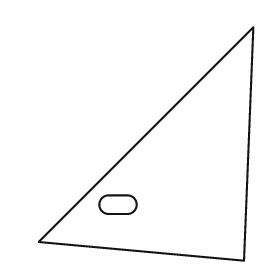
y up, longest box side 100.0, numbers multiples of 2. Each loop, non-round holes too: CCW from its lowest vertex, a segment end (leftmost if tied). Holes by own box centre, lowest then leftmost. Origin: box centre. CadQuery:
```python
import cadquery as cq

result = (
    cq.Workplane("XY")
    .moveTo(42.0, -50.0)
    .lineTo(46.0, 50.0)
    .lineTo(-46.0, -42.0)
    .close()
    .moveTo(-16.0, -30.0)
    .lineTo(-8.0, -30.0)
    .threePointArc((-4.0, -26.0), (-8.0, -22.0))
    .lineTo(-16.0, -22.0)
    .threePointArc((-20.0, -26.0), (-16.0, -30.0))
    .close()
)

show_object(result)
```